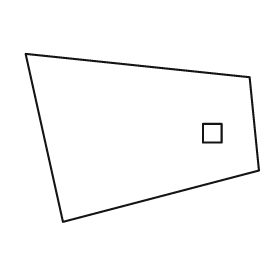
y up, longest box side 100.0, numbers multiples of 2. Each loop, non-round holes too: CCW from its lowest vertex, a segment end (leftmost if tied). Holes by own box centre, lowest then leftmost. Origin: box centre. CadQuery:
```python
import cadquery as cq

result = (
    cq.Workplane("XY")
    .moveTo(-34.0, -36.0)
    .lineTo(50.0, -14.0)
    .lineTo(46.0, 26.0)
    .lineTo(-50.0, 36.0)
    .close()
    .moveTo(26.0, -2.0)
    .lineTo(34.0, -2.0)
    .lineTo(34.0, 6.0)
    .lineTo(26.0, 6.0)
    .close()
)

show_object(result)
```